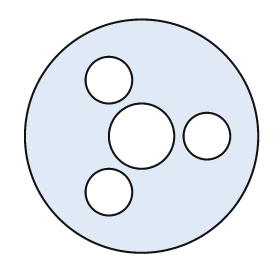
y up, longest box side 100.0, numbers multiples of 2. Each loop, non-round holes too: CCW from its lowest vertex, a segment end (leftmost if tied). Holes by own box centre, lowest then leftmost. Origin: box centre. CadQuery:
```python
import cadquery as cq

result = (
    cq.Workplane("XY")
    .moveTo(0.0, 0.0)
    .circle(50.0)
    .moveTo(-14.0, -24.0)
    .circle(10.0)
    .moveTo(0.0, 0.0)
    .circle(14.0)
    .moveTo(28.0, 0.0)
    .circle(10.0)
    .moveTo(-14.0, 24.0)
    .circle(10.0)
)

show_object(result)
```